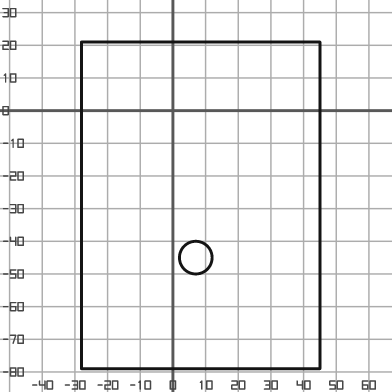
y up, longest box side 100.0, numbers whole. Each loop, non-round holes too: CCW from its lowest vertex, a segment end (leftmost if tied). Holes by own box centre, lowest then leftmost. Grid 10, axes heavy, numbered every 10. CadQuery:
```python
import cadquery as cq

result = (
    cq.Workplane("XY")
    .moveTo(-28.0, -79.0)
    .lineTo(45.0, -79.0)
    .lineTo(45.0, 21.0)
    .lineTo(-28.0, 21.0)
    .close()
    .moveTo(7.0, -45.0)
    .circle(5.0)
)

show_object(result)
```